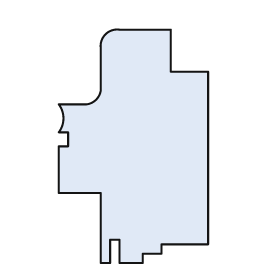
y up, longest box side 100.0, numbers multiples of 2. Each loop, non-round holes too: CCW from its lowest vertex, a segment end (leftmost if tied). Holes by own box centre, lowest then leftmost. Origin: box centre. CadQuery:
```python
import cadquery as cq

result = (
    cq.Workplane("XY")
    .moveTo(-14.0, -50.0)
    .lineTo(-10.0, -50.0)
    .lineTo(-10.0, -40.0)
    .lineTo(-6.0, -40.0)
    .lineTo(-6.0, -50.0)
    .lineTo(4.0, -50.0)
    .lineTo(4.0, -46.0)
    .lineTo(12.0, -46.0)
    .lineTo(12.0, -42.0)
    .lineTo(32.0, -42.0)
    .lineTo(32.0, 32.0)
    .lineTo(16.0, 32.0)
    .lineTo(16.0, 50.0)
    .lineTo(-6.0, 50.0)
    .threePointArc((-12.0, 48.0), (-14.0, 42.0))
    .lineTo(-14.0, 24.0)
    .threePointArc((-16.0, 20.0), (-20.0, 18.0))
    .lineTo(-32.0, 18.0)
    .threePointArc((-30.0, 12.0), (-32.0, 6.0))
    .lineTo(-28.0, 6.0)
    .lineTo(-28.0, 0.0)
    .lineTo(-32.0, 0.0)
    .lineTo(-32.0, -20.0)
    .lineTo(-14.0, -20.0)
    .close()
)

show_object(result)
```